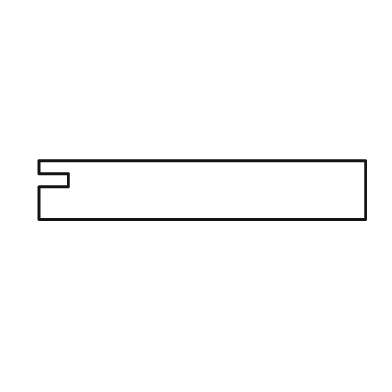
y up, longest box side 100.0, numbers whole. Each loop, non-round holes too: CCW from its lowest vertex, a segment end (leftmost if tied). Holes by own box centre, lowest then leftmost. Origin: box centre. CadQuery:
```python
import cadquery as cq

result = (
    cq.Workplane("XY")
    .moveTo(-50.0, -9.0)
    .lineTo(50.0, -9.0)
    .lineTo(50.0, 9.0)
    .lineTo(-50.0, 9.0)
    .lineTo(-50.0, 5.0)
    .lineTo(-41.0, 5.0)
    .lineTo(-41.0, 1.0)
    .lineTo(-50.0, 1.0)
    .close()
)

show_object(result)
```